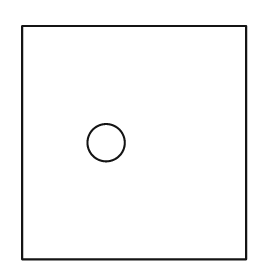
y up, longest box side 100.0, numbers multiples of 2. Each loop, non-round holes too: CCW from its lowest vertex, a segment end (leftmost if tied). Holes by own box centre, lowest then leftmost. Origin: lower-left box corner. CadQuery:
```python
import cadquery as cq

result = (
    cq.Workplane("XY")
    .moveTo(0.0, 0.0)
    .lineTo(96.0, 0.0)
    .lineTo(96.0, 100.0)
    .lineTo(0.0, 100.0)
    .close()
    .moveTo(36.0, 50.0)
    .circle(8.0)
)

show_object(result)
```